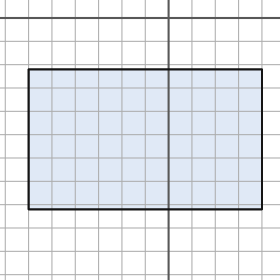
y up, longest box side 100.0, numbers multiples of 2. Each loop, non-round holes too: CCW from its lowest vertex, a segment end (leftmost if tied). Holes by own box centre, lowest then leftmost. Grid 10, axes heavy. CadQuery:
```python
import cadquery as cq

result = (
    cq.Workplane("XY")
    .moveTo(-60.0, -82.0)
    .lineTo(40.0, -82.0)
    .lineTo(40.0, -22.0)
    .lineTo(-60.0, -22.0)
    .close()
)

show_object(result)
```